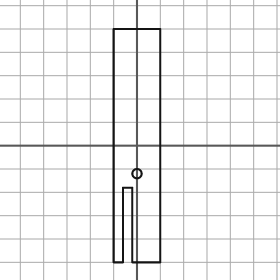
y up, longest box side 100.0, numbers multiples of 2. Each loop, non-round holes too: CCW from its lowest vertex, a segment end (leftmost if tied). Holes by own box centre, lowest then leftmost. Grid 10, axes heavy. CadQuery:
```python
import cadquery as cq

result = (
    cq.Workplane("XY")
    .moveTo(-10.0, -50.0)
    .lineTo(-6.0, -50.0)
    .lineTo(-6.0, -18.0)
    .lineTo(-2.0, -18.0)
    .lineTo(-2.0, -50.0)
    .lineTo(10.0, -50.0)
    .lineTo(10.0, 50.0)
    .lineTo(-10.0, 50.0)
    .close()
    .moveTo(0.0, -12.0)
    .circle(2.0)
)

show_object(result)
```